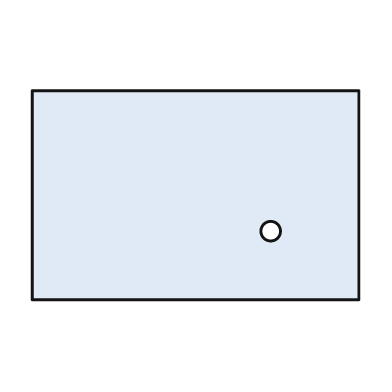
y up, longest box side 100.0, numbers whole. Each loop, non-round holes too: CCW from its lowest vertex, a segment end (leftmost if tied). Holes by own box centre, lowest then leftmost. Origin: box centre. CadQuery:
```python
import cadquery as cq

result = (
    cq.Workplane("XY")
    .moveTo(-50.0, -32.0)
    .lineTo(50.0, -32.0)
    .lineTo(50.0, 32.0)
    .lineTo(-50.0, 32.0)
    .close()
    .moveTo(23.0, -11.0)
    .circle(3.0)
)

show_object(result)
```